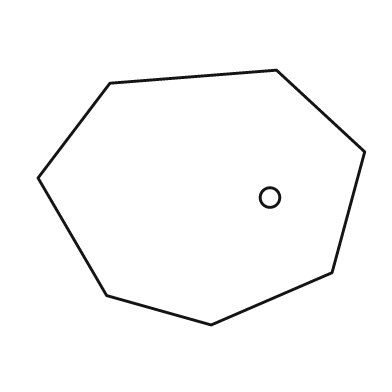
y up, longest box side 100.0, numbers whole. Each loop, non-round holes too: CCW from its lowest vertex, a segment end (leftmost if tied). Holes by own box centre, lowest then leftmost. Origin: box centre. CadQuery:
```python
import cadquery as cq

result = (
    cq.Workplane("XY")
    .moveTo(3.0, -39.0)
    .lineTo(40.0, -23.0)
    .lineTo(50.0, 14.0)
    .lineTo(23.0, 39.0)
    .lineTo(-28.0, 35.0)
    .lineTo(-50.0, 6.0)
    .lineTo(-29.0, -30.0)
    .close()
    .moveTo(21.0, 0.0)
    .circle(3.0)
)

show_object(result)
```